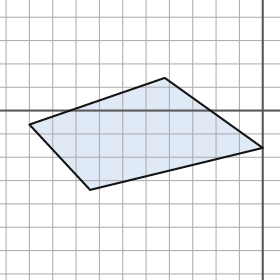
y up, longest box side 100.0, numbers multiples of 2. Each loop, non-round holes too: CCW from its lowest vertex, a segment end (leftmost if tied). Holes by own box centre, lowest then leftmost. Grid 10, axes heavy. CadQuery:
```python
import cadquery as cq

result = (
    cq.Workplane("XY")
    .moveTo(-74.0, -34.0)
    .lineTo(0.0, -16.0)
    .lineTo(-42.0, 14.0)
    .lineTo(-100.0, -6.0)
    .close()
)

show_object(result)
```